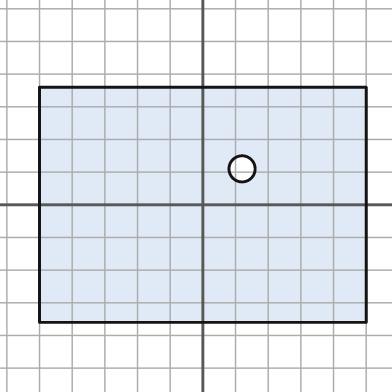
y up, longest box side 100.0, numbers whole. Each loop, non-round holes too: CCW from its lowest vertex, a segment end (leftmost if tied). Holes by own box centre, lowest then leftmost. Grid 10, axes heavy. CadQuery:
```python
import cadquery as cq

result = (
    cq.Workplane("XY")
    .moveTo(-50.0, -36.0)
    .lineTo(50.0, -36.0)
    .lineTo(50.0, 36.0)
    .lineTo(-50.0, 36.0)
    .close()
    .moveTo(12.0, 11.0)
    .circle(4.0)
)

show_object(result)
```